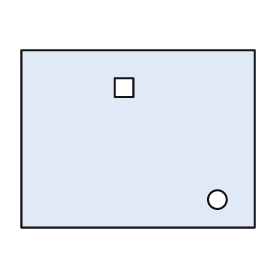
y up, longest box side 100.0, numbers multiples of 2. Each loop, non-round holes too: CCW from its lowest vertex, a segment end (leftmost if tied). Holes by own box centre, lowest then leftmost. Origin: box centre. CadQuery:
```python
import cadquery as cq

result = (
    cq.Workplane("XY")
    .moveTo(-50.0, -38.0)
    .lineTo(50.0, -38.0)
    .lineTo(50.0, 38.0)
    .lineTo(-50.0, 38.0)
    .close()
    .moveTo(34.0, -26.0)
    .circle(4.0)
    .moveTo(-10.0, 18.0)
    .lineTo(-2.0, 18.0)
    .lineTo(-2.0, 26.0)
    .lineTo(-10.0, 26.0)
    .close()
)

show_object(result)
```